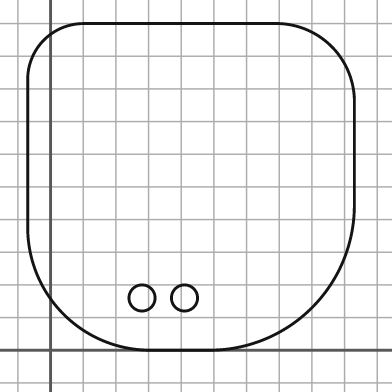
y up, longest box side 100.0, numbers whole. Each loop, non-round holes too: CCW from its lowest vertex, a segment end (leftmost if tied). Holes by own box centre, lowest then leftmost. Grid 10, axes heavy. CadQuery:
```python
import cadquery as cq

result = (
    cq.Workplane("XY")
    .moveTo(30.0, 0.0)
    .lineTo(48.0, 0.0)
    .threePointArc((80.0, 13.0), (93.0, 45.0))
    .lineTo(93.0, 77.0)
    .threePointArc((86.0, 93.0), (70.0, 100.0))
    .lineTo(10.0, 100.0)
    .threePointArc((-2.0, 95.0), (-7.0, 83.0))
    .lineTo(-7.0, 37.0)
    .threePointArc((4.0, 11.0), (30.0, 0.0))
    .close()
    .moveTo(28.0, 16.0)
    .circle(4.0)
    .moveTo(41.0, 16.0)
    .circle(4.0)
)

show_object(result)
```